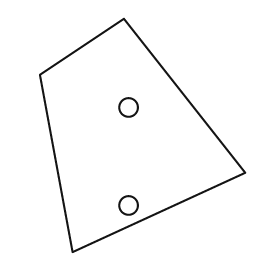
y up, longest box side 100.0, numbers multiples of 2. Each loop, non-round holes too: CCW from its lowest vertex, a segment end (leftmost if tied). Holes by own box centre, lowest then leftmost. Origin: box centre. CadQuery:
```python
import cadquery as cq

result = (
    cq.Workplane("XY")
    .moveTo(-30.0, -50.0)
    .lineTo(44.0, -16.0)
    .lineTo(-8.0, 50.0)
    .lineTo(-44.0, 26.0)
    .close()
    .moveTo(-6.0, -30.0)
    .circle(4.0)
    .moveTo(-6.0, 12.0)
    .circle(4.0)
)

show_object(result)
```